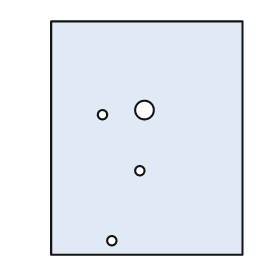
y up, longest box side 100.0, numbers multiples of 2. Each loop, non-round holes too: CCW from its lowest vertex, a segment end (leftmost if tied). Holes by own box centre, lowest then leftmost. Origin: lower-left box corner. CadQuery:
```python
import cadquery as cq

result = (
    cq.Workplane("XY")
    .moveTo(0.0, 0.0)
    .lineTo(82.0, 0.0)
    .lineTo(82.0, 100.0)
    .lineTo(0.0, 100.0)
    .close()
    .moveTo(26.0, 6.0)
    .circle(2.0)
    .moveTo(38.0, 36.0)
    .circle(2.0)
    .moveTo(22.0, 60.0)
    .circle(2.0)
    .moveTo(40.0, 62.0)
    .circle(4.0)
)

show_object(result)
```